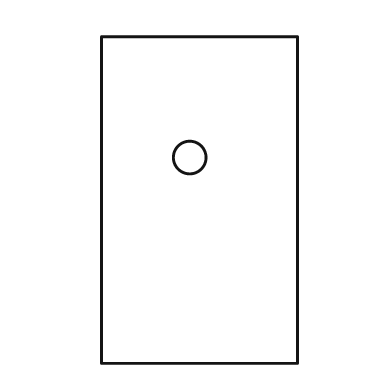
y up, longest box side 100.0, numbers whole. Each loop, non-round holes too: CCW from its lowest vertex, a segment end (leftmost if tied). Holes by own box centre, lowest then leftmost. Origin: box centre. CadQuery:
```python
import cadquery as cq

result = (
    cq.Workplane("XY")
    .moveTo(-30.0, -50.0)
    .lineTo(30.0, -50.0)
    .lineTo(30.0, 50.0)
    .lineTo(-30.0, 50.0)
    .close()
    .moveTo(-3.0, 13.0)
    .circle(5.0)
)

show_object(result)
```